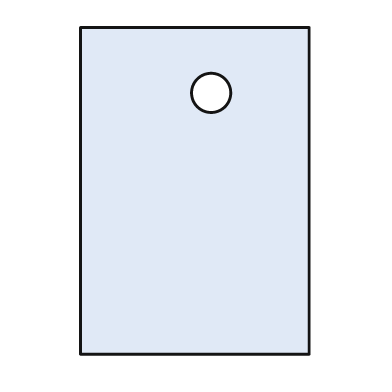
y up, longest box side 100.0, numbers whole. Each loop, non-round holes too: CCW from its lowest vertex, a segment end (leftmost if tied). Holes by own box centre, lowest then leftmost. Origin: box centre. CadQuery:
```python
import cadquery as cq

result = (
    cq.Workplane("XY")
    .moveTo(-35.0, -50.0)
    .lineTo(35.0, -50.0)
    .lineTo(35.0, 50.0)
    .lineTo(-35.0, 50.0)
    .close()
    .moveTo(5.0, 30.0)
    .circle(6.0)
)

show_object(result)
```